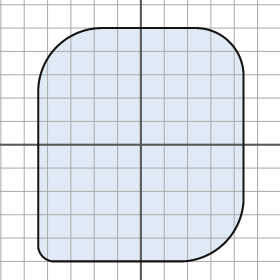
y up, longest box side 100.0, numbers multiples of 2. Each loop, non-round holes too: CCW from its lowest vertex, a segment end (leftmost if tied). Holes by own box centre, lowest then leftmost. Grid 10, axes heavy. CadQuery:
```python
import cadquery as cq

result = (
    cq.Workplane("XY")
    .moveTo(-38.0, -50.0)
    .lineTo(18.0, -50.0)
    .threePointArc((36.0, -42.0), (44.0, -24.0))
    .lineTo(44.0, 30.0)
    .threePointArc((38.0, 44.0), (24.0, 50.0))
    .lineTo(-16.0, 50.0)
    .threePointArc((-36.0, 42.0), (-44.0, 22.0))
    .lineTo(-44.0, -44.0)
    .threePointArc((-42.0, -48.0), (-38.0, -50.0))
    .close()
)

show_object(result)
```